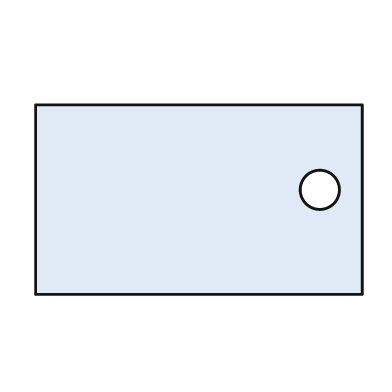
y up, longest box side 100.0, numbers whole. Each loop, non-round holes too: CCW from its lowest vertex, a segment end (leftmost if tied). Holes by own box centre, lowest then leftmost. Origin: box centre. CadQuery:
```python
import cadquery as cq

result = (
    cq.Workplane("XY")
    .moveTo(-50.0, -29.0)
    .lineTo(50.0, -29.0)
    .lineTo(50.0, 29.0)
    .lineTo(-50.0, 29.0)
    .close()
    .moveTo(37.0, 3.0)
    .circle(6.0)
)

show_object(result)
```